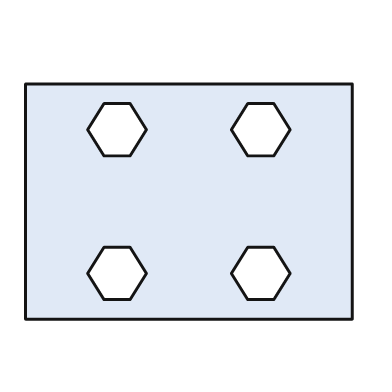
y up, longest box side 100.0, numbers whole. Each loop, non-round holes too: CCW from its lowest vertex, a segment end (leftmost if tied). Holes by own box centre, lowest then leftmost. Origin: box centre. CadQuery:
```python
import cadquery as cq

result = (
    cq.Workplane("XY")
    .moveTo(-50.0, -36.0)
    .lineTo(50.0, -36.0)
    .lineTo(50.0, 36.0)
    .lineTo(-50.0, 36.0)
    .close()
    .moveTo(-26.0, -30.0)
    .lineTo(-18.0, -30.0)
    .lineTo(-13.0, -22.0)
    .lineTo(-18.0, -14.0)
    .lineTo(-26.0, -14.0)
    .lineTo(-31.0, -22.0)
    .close()
    .moveTo(18.0, -30.0)
    .lineTo(26.0, -30.0)
    .lineTo(31.0, -22.0)
    .lineTo(26.0, -14.0)
    .lineTo(18.0, -14.0)
    .lineTo(13.0, -22.0)
    .close()
    .moveTo(-26.0, 14.0)
    .lineTo(-18.0, 14.0)
    .lineTo(-13.0, 22.0)
    .lineTo(-18.0, 30.0)
    .lineTo(-26.0, 30.0)
    .lineTo(-31.0, 22.0)
    .close()
    .moveTo(18.0, 14.0)
    .lineTo(26.0, 14.0)
    .lineTo(31.0, 22.0)
    .lineTo(26.0, 30.0)
    .lineTo(18.0, 30.0)
    .lineTo(13.0, 22.0)
    .close()
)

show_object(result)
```